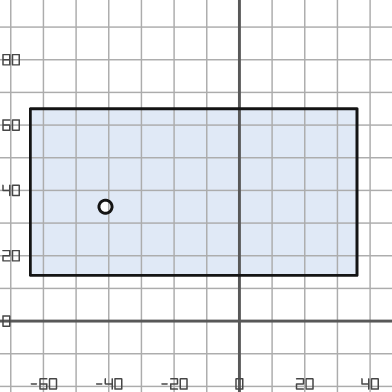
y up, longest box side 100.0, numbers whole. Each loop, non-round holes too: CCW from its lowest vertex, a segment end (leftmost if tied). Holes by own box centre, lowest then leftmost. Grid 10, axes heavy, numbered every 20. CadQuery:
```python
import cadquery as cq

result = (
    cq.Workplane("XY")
    .moveTo(-64.0, 14.0)
    .lineTo(36.0, 14.0)
    .lineTo(36.0, 65.0)
    .lineTo(-64.0, 65.0)
    .close()
    .moveTo(-41.0, 35.0)
    .circle(2.0)
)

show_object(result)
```